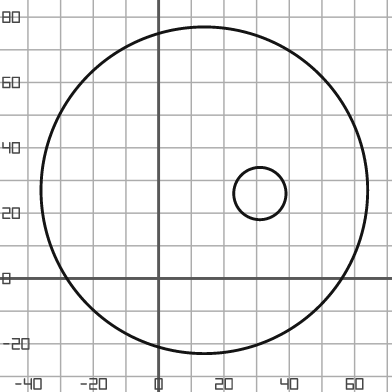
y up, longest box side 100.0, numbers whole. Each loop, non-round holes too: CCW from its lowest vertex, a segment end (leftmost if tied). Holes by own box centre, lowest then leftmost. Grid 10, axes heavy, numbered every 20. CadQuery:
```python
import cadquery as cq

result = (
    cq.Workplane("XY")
    .moveTo(14.0, 27.0)
    .circle(50.0)
    .moveTo(31.0, 26.0)
    .circle(8.0)
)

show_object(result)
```